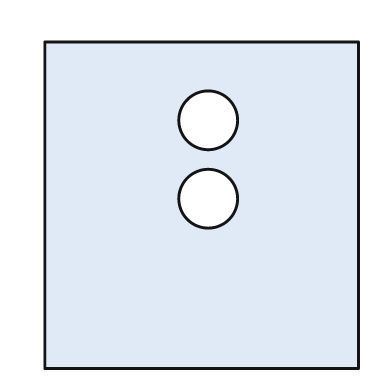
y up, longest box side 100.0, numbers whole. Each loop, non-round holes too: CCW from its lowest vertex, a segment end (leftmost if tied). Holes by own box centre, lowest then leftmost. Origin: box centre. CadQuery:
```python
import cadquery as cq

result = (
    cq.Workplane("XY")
    .moveTo(-48.0, -50.0)
    .lineTo(48.0, -50.0)
    .lineTo(48.0, 50.0)
    .lineTo(-48.0, 50.0)
    .close()
    .moveTo(2.0, 2.0)
    .circle(9.0)
    .moveTo(2.0, 26.0)
    .circle(9.0)
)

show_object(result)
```